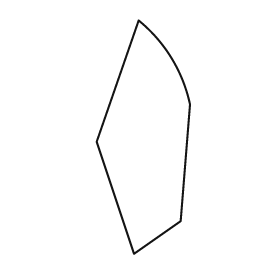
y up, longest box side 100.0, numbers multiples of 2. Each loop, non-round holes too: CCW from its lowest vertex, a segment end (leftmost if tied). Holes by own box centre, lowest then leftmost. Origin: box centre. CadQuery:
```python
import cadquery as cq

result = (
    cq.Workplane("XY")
    .moveTo(-4.0, -50.0)
    .lineTo(16.0, -36.0)
    .lineTo(20.0, 14.0)
    .threePointArc((12.0, 34.0), (-2.0, 50.0))
    .lineTo(-20.0, -2.0)
    .close()
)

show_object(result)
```